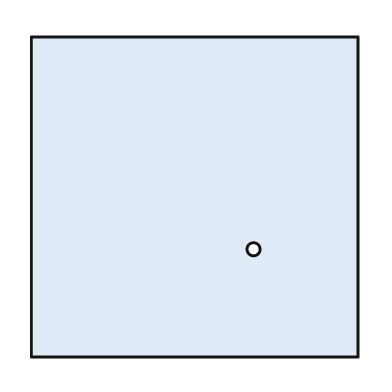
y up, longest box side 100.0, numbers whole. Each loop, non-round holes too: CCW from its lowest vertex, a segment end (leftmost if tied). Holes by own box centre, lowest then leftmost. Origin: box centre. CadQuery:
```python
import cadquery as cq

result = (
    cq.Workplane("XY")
    .moveTo(-50.0, -49.0)
    .lineTo(50.0, -49.0)
    .lineTo(50.0, 49.0)
    .lineTo(-50.0, 49.0)
    .close()
    .moveTo(18.0, -16.0)
    .circle(2.0)
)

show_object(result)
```